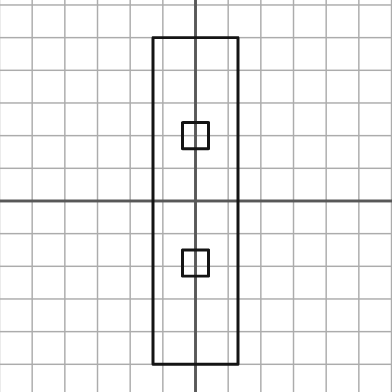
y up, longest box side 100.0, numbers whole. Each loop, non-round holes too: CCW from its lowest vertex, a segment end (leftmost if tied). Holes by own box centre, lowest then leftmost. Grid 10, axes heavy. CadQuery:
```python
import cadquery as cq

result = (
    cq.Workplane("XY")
    .moveTo(-13.0, -50.0)
    .lineTo(13.0, -50.0)
    .lineTo(13.0, 50.0)
    .lineTo(-13.0, 50.0)
    .close()
    .moveTo(-4.0, -23.0)
    .lineTo(4.0, -23.0)
    .lineTo(4.0, -15.0)
    .lineTo(-4.0, -15.0)
    .close()
    .moveTo(-4.0, 16.0)
    .lineTo(4.0, 16.0)
    .lineTo(4.0, 24.0)
    .lineTo(-4.0, 24.0)
    .close()
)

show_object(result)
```